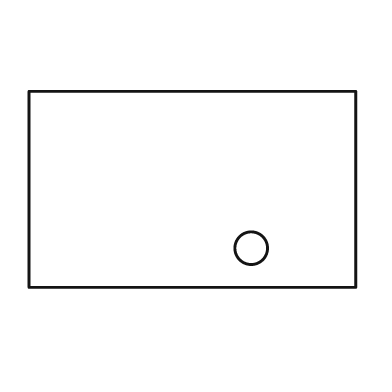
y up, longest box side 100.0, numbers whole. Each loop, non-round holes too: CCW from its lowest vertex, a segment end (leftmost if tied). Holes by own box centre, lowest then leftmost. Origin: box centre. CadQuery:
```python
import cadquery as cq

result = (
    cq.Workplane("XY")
    .moveTo(-50.0, -30.0)
    .lineTo(50.0, -30.0)
    .lineTo(50.0, 30.0)
    .lineTo(-50.0, 30.0)
    .close()
    .moveTo(18.0, -18.0)
    .circle(5.0)
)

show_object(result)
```